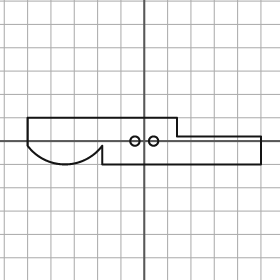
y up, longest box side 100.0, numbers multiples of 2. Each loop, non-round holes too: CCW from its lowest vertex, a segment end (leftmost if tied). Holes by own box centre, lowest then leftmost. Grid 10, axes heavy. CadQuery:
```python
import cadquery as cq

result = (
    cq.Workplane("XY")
    .moveTo(-18.0, -10.0)
    .lineTo(50.0, -10.0)
    .lineTo(50.0, 2.0)
    .lineTo(14.0, 2.0)
    .lineTo(14.0, 10.0)
    .lineTo(-50.0, 10.0)
    .lineTo(-50.0, -2.0)
    .threePointArc((-34.0, -10.0), (-18.0, -2.0))
    .close()
    .moveTo(-4.0, 0.0)
    .circle(2.0)
    .moveTo(4.0, 0.0)
    .circle(2.0)
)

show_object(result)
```